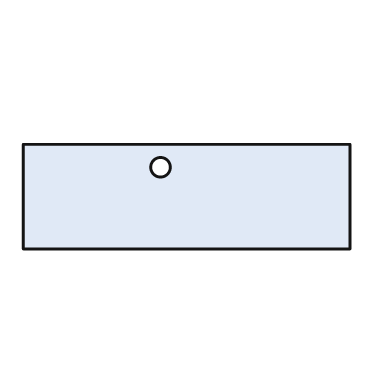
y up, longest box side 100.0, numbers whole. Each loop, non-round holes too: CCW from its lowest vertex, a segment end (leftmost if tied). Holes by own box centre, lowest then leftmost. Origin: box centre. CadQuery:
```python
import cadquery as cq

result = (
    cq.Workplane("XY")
    .moveTo(-50.0, -16.0)
    .lineTo(50.0, -16.0)
    .lineTo(50.0, 16.0)
    .lineTo(-50.0, 16.0)
    .close()
    .moveTo(-8.0, 9.0)
    .circle(3.0)
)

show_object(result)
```